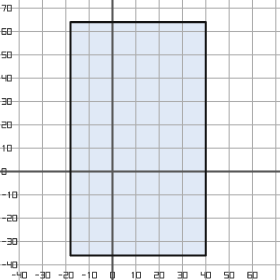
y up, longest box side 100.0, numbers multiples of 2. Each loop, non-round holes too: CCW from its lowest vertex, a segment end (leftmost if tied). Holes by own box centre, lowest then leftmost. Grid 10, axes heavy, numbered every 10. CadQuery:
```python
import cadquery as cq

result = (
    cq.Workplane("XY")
    .moveTo(-18.0, -36.0)
    .lineTo(40.0, -36.0)
    .lineTo(40.0, 64.0)
    .lineTo(-18.0, 64.0)
    .close()
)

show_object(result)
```